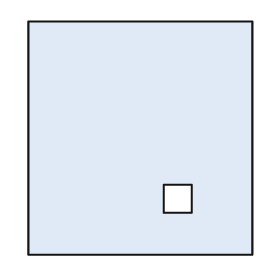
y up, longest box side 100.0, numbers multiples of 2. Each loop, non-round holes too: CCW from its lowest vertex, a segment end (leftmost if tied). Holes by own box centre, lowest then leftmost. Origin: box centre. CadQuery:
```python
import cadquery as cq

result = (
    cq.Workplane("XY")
    .moveTo(-48.0, -50.0)
    .lineTo(48.0, -50.0)
    .lineTo(48.0, 50.0)
    .lineTo(-48.0, 50.0)
    .close()
    .moveTo(10.0, -32.0)
    .lineTo(22.0, -32.0)
    .lineTo(22.0, -20.0)
    .lineTo(10.0, -20.0)
    .close()
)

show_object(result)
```